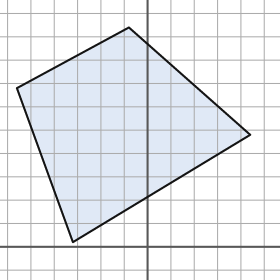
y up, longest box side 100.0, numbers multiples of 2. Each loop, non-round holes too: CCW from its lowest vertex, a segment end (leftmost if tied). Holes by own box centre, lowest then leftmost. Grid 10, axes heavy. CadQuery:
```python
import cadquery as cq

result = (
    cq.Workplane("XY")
    .moveTo(-32.0, 2.0)
    .lineTo(44.0, 48.0)
    .lineTo(-8.0, 94.0)
    .lineTo(-56.0, 68.0)
    .close()
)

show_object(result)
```